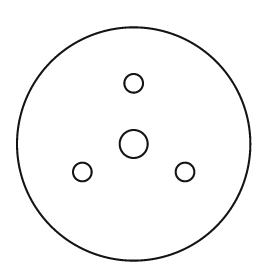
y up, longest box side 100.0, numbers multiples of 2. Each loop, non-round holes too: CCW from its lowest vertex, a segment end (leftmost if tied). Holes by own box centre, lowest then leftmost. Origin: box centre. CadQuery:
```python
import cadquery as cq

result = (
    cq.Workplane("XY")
    .moveTo(0.0, 0.0)
    .circle(50.0)
    .moveTo(-22.0, -12.0)
    .circle(4.0)
    .moveTo(22.0, -12.0)
    .circle(4.0)
    .moveTo(0.0, 0.0)
    .circle(6.0)
    .moveTo(0.0, 26.0)
    .circle(4.0)
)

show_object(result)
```